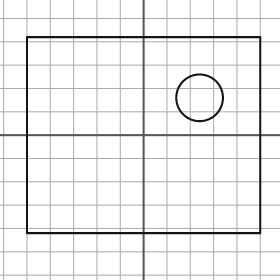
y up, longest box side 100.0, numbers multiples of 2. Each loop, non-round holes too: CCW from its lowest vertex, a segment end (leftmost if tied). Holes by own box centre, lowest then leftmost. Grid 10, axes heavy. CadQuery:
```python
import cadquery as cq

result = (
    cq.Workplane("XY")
    .moveTo(-50.0, -42.0)
    .lineTo(50.0, -42.0)
    .lineTo(50.0, 42.0)
    .lineTo(-50.0, 42.0)
    .close()
    .moveTo(24.0, 16.0)
    .circle(10.0)
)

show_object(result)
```